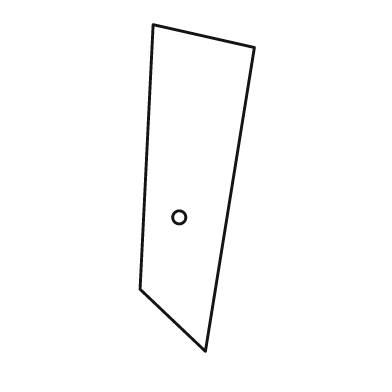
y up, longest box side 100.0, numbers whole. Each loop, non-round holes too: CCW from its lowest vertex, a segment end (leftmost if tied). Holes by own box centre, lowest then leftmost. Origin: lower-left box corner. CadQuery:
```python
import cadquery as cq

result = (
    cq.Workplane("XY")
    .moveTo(20.0, 0.0)
    .lineTo(35.0, 93.0)
    .lineTo(4.0, 100.0)
    .lineTo(0.0, 19.0)
    .close()
    .moveTo(12.0, 41.0)
    .circle(2.0)
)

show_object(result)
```